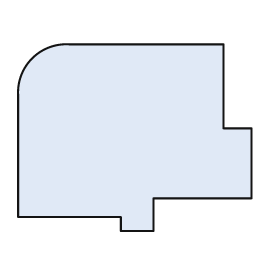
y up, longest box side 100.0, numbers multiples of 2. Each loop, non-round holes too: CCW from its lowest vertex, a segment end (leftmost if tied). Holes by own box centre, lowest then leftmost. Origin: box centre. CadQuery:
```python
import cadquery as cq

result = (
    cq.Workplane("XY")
    .moveTo(-6.0, -40.0)
    .lineTo(8.0, -40.0)
    .lineTo(8.0, -26.0)
    .lineTo(50.0, -26.0)
    .lineTo(50.0, 4.0)
    .lineTo(38.0, 4.0)
    .lineTo(38.0, 40.0)
    .lineTo(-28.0, 40.0)
    .threePointArc((-44.0, 34.0), (-50.0, 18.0))
    .lineTo(-50.0, -34.0)
    .lineTo(-6.0, -34.0)
    .close()
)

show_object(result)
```